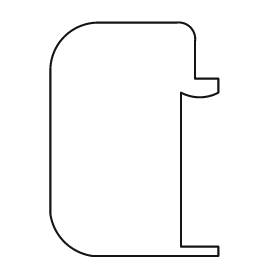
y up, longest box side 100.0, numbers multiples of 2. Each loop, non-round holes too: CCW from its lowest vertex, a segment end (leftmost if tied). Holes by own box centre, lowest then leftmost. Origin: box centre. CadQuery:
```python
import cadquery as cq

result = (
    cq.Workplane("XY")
    .moveTo(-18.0, -50.0)
    .lineTo(36.0, -50.0)
    .lineTo(36.0, -46.0)
    .lineTo(20.0, -46.0)
    .lineTo(20.0, 20.0)
    .threePointArc((28.0, 18.0), (36.0, 20.0))
    .lineTo(36.0, 26.0)
    .lineTo(26.0, 26.0)
    .lineTo(26.0, 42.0)
    .threePointArc((24.0, 48.0), (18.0, 50.0))
    .lineTo(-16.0, 50.0)
    .threePointArc((-30.0, 44.0), (-36.0, 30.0))
    .lineTo(-36.0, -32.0)
    .threePointArc((-30.0, -44.0), (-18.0, -50.0))
    .close()
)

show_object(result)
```